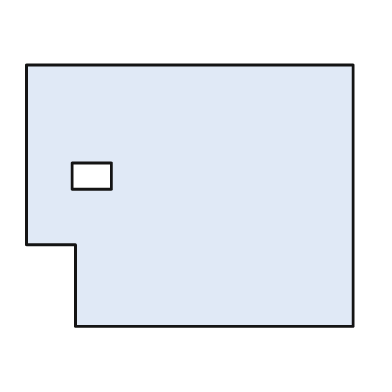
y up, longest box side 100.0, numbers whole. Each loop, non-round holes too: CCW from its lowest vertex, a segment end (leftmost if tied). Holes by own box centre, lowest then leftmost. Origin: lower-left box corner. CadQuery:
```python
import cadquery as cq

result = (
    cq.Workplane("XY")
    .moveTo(15.0, 0.0)
    .lineTo(100.0, 0.0)
    .lineTo(100.0, 80.0)
    .lineTo(0.0, 80.0)
    .lineTo(0.0, 25.0)
    .lineTo(15.0, 25.0)
    .close()
    .moveTo(14.0, 42.0)
    .lineTo(26.0, 42.0)
    .lineTo(26.0, 50.0)
    .lineTo(14.0, 50.0)
    .close()
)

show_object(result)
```